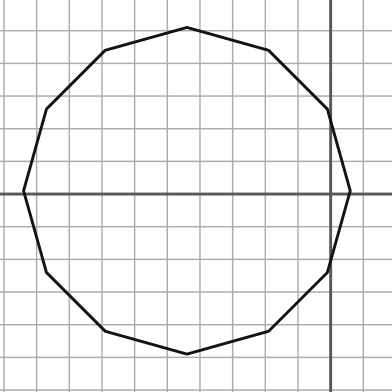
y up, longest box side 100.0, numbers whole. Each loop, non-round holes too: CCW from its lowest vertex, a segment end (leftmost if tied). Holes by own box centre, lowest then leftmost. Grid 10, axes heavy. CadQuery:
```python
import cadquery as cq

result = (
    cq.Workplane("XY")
    .moveTo(-44.0, -49.0)
    .lineTo(-19.0, -42.0)
    .lineTo(-1.0, -24.0)
    .lineTo(6.0, 1.0)
    .lineTo(-1.0, 26.0)
    .lineTo(-19.0, 44.0)
    .lineTo(-44.0, 51.0)
    .lineTo(-69.0, 44.0)
    .lineTo(-87.0, 26.0)
    .lineTo(-94.0, 1.0)
    .lineTo(-87.0, -24.0)
    .lineTo(-69.0, -42.0)
    .close()
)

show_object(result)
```